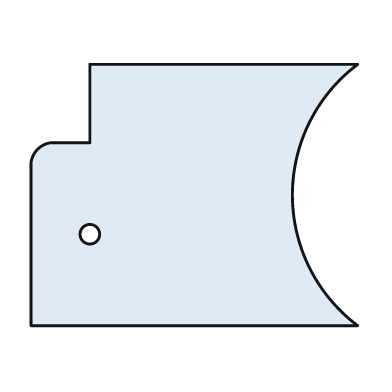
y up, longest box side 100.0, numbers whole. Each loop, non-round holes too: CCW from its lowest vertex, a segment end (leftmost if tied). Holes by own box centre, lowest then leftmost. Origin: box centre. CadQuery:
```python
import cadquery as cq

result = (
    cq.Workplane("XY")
    .moveTo(-50.0, -40.0)
    .lineTo(50.0, -40.0)
    .threePointArc((30.0, 0.0), (50.0, 40.0))
    .lineTo(-32.0, 40.0)
    .lineTo(-32.0, 16.0)
    .lineTo(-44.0, 16.0)
    .threePointArc((-48.0, 14.0), (-50.0, 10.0))
    .close()
    .moveTo(-32.0, -12.0)
    .circle(3.0)
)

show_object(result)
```